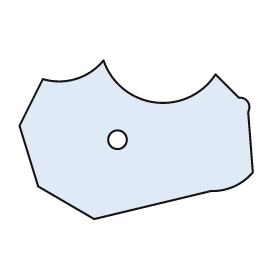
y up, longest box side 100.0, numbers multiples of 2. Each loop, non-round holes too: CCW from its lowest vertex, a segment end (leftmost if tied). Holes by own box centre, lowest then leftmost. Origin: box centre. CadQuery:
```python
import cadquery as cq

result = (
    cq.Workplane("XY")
    .moveTo(-18.0, -34.0)
    .lineTo(32.0, -22.0)
    .threePointArc((42.0, -20.0), (50.0, -14.0))
    .lineTo(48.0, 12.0)
    .threePointArc((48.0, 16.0), (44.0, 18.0))
    .lineTo(34.0, 28.0)
    .threePointArc((8.0, 16.0), (-14.0, 34.0))
    .threePointArc((-26.0, 26.0), (-40.0, 26.0))
    .lineTo(-50.0, 6.0)
    .lineTo(-42.0, -20.0)
    .close()
    .moveTo(-8.0, 0.0)
    .circle(4.0)
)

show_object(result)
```